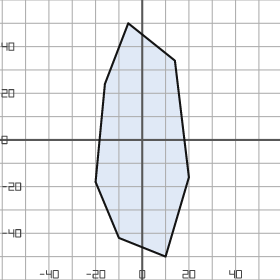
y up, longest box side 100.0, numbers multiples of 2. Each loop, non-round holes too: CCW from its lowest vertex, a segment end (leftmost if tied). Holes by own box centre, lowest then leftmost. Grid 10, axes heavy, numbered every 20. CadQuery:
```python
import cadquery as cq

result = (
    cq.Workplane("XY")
    .moveTo(10.0, -50.0)
    .lineTo(20.0, -16.0)
    .lineTo(14.0, 34.0)
    .lineTo(-6.0, 50.0)
    .lineTo(-16.0, 24.0)
    .lineTo(-20.0, -18.0)
    .lineTo(-10.0, -42.0)
    .close()
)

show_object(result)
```